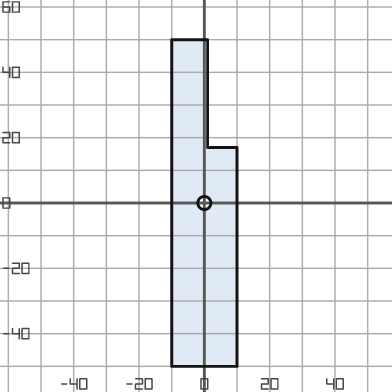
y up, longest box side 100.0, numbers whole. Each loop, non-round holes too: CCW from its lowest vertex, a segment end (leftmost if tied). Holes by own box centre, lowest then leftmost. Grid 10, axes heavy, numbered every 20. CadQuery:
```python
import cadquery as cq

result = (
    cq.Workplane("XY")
    .moveTo(-10.0, -50.0)
    .lineTo(10.0, -50.0)
    .lineTo(10.0, 17.0)
    .lineTo(1.0, 17.0)
    .lineTo(1.0, 50.0)
    .lineTo(-10.0, 50.0)
    .close()
    .moveTo(0.0, 0.0)
    .circle(2.0)
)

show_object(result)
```